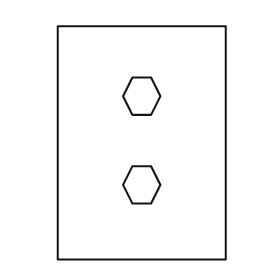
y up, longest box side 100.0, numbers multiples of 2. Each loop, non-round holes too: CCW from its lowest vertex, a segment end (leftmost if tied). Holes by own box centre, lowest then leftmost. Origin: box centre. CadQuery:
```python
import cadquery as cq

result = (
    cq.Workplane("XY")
    .moveTo(-36.0, -50.0)
    .lineTo(36.0, -50.0)
    .lineTo(36.0, 50.0)
    .lineTo(-36.0, 50.0)
    .close()
    .moveTo(-4.0, -26.0)
    .lineTo(4.0, -26.0)
    .lineTo(8.0, -18.0)
    .lineTo(4.0, -10.0)
    .lineTo(-4.0, -10.0)
    .lineTo(-8.0, -18.0)
    .close()
    .moveTo(-4.0, 12.0)
    .lineTo(4.0, 12.0)
    .lineTo(8.0, 20.0)
    .lineTo(4.0, 28.0)
    .lineTo(-4.0, 28.0)
    .lineTo(-8.0, 20.0)
    .close()
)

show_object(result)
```